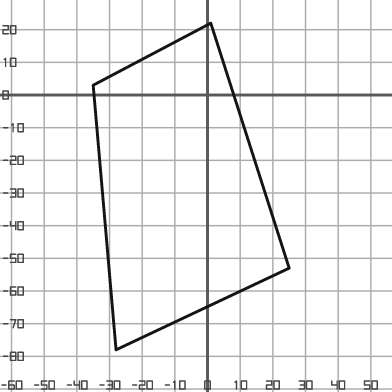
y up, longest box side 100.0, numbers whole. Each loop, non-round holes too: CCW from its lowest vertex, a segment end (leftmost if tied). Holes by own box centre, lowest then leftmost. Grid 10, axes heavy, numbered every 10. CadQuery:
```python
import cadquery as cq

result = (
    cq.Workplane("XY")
    .moveTo(-28.0, -78.0)
    .lineTo(25.0, -53.0)
    .lineTo(1.0, 22.0)
    .lineTo(-35.0, 3.0)
    .close()
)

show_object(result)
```